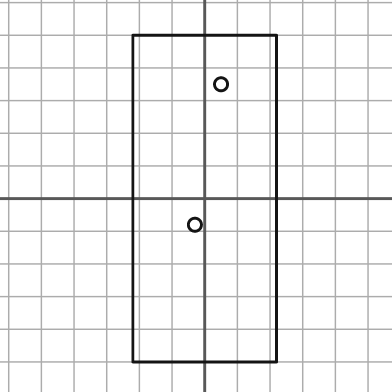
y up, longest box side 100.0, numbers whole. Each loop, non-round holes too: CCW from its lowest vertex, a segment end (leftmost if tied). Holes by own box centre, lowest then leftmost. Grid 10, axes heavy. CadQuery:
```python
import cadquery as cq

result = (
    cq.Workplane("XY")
    .moveTo(-22.0, -50.0)
    .lineTo(22.0, -50.0)
    .lineTo(22.0, 50.0)
    .lineTo(-22.0, 50.0)
    .close()
    .moveTo(-3.0, -8.0)
    .circle(2.0)
    .moveTo(5.0, 35.0)
    .circle(2.0)
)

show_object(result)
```